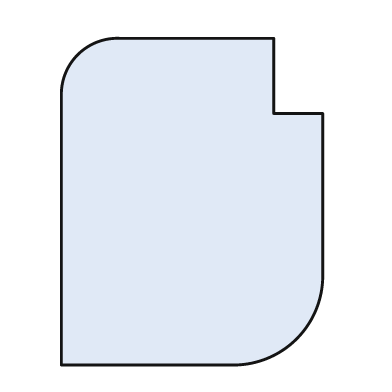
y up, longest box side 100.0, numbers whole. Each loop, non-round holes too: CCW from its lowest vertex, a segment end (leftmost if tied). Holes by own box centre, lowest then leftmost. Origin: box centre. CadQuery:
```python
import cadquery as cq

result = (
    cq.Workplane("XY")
    .moveTo(-40.0, -50.0)
    .lineTo(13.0, -50.0)
    .threePointArc((32.0, -42.0), (40.0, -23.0))
    .lineTo(40.0, 27.0)
    .lineTo(25.0, 27.0)
    .lineTo(25.0, 50.0)
    .lineTo(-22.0, 50.0)
    .threePointArc((-35.0, 45.0), (-40.0, 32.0))
    .close()
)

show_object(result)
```